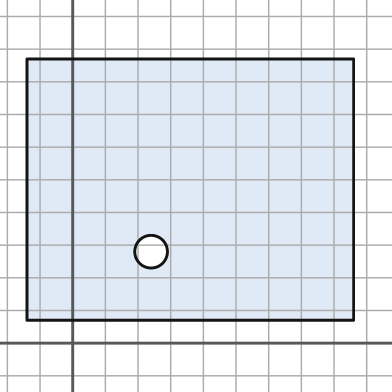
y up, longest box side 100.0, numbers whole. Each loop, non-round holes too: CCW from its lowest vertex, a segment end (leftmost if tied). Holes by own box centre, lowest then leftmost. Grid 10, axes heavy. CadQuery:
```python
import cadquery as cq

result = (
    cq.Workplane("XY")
    .moveTo(-14.0, 7.0)
    .lineTo(86.0, 7.0)
    .lineTo(86.0, 87.0)
    .lineTo(-14.0, 87.0)
    .close()
    .moveTo(24.0, 28.0)
    .circle(5.0)
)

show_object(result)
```